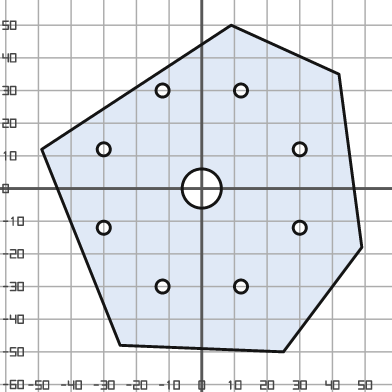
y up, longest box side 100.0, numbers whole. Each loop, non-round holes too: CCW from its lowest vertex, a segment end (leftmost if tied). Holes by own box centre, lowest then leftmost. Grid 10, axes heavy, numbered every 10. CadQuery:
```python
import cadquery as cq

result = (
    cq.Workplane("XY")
    .moveTo(25.0, -50.0)
    .lineTo(49.0, -18.0)
    .lineTo(42.0, 35.0)
    .lineTo(9.0, 50.0)
    .lineTo(-49.0, 12.0)
    .lineTo(-25.0, -48.0)
    .close()
    .moveTo(-12.0, -30.0)
    .circle(2.0)
    .moveTo(12.0, -30.0)
    .circle(2.0)
    .moveTo(-30.0, -12.0)
    .circle(2.0)
    .moveTo(30.0, -12.0)
    .circle(2.0)
    .moveTo(0.0, 0.0)
    .circle(6.0)
    .moveTo(-30.0, 12.0)
    .circle(2.0)
    .moveTo(30.0, 12.0)
    .circle(2.0)
    .moveTo(-12.0, 30.0)
    .circle(2.0)
    .moveTo(12.0, 30.0)
    .circle(2.0)
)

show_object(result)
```